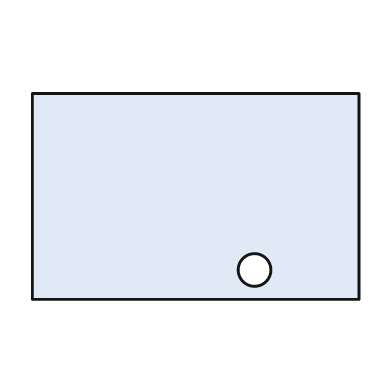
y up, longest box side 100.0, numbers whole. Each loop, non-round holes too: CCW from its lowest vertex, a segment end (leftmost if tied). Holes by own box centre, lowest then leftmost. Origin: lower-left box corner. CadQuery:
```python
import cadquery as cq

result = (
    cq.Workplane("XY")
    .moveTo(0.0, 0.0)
    .lineTo(100.0, 0.0)
    .lineTo(100.0, 63.0)
    .lineTo(0.0, 63.0)
    .close()
    .moveTo(68.0, 9.0)
    .circle(5.0)
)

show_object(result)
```